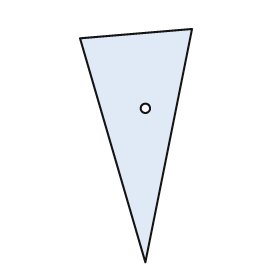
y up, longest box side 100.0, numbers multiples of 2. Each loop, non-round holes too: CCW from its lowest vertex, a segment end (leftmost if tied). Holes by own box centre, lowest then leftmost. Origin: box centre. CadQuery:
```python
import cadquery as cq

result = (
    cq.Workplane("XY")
    .moveTo(4.0, -50.0)
    .lineTo(24.0, 50.0)
    .lineTo(-24.0, 46.0)
    .close()
    .moveTo(4.0, 16.0)
    .circle(2.0)
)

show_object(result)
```